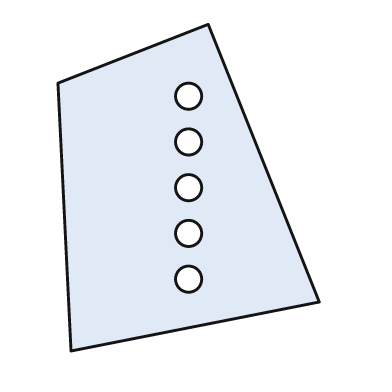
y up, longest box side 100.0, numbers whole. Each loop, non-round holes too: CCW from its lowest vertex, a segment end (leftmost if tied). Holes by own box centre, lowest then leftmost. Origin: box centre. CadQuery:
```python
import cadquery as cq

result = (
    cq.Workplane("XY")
    .moveTo(-36.0, -50.0)
    .lineTo(40.0, -35.0)
    .lineTo(6.0, 50.0)
    .lineTo(-40.0, 32.0)
    .close()
    .moveTo(0.0, -28.0)
    .circle(4.0)
    .moveTo(0.0, -14.0)
    .circle(4.0)
    .moveTo(0.0, 0.0)
    .circle(4.0)
    .moveTo(0.0, 14.0)
    .circle(4.0)
    .moveTo(0.0, 28.0)
    .circle(4.0)
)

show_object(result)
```